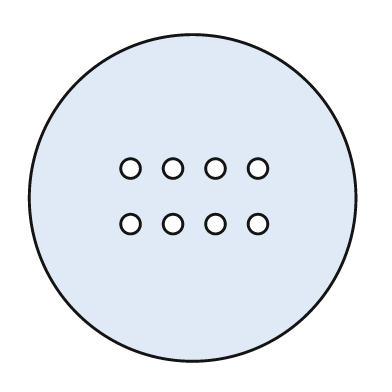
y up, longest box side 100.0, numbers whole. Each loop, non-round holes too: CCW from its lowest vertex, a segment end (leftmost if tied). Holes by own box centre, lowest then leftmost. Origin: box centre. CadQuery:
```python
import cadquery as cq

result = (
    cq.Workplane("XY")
    .moveTo(0.0, 0.0)
    .circle(50.0)
    .moveTo(-19.0, -8.0)
    .circle(3.0)
    .moveTo(-6.0, -8.0)
    .circle(3.0)
    .moveTo(7.0, -8.0)
    .circle(3.0)
    .moveTo(20.0, -8.0)
    .circle(3.0)
    .moveTo(-19.0, 9.0)
    .circle(3.0)
    .moveTo(-6.0, 9.0)
    .circle(3.0)
    .moveTo(7.0, 9.0)
    .circle(3.0)
    .moveTo(20.0, 9.0)
    .circle(3.0)
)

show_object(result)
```